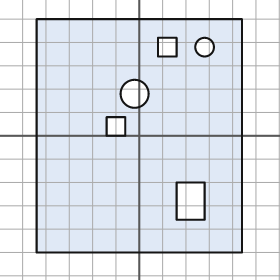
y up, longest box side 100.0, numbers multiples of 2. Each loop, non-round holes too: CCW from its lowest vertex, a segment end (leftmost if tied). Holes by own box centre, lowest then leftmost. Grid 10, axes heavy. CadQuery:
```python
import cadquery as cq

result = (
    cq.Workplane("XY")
    .moveTo(-44.0, -50.0)
    .lineTo(44.0, -50.0)
    .lineTo(44.0, 50.0)
    .lineTo(-44.0, 50.0)
    .close()
    .moveTo(16.0, -36.0)
    .lineTo(28.0, -36.0)
    .lineTo(28.0, -20.0)
    .lineTo(16.0, -20.0)
    .close()
    .moveTo(-14.0, 0.0)
    .lineTo(-6.0, 0.0)
    .lineTo(-6.0, 8.0)
    .lineTo(-14.0, 8.0)
    .close()
    .moveTo(-2.0, 18.0)
    .circle(6.0)
    .moveTo(8.0, 34.0)
    .lineTo(16.0, 34.0)
    .lineTo(16.0, 42.0)
    .lineTo(8.0, 42.0)
    .close()
    .moveTo(28.0, 38.0)
    .circle(4.0)
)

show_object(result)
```